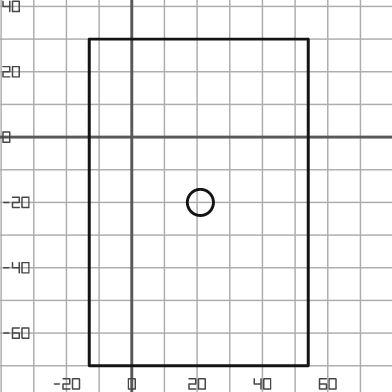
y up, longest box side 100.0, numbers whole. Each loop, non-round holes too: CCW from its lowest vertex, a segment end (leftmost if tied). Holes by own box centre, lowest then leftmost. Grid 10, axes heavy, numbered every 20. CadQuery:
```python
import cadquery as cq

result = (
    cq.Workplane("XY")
    .moveTo(-13.0, -70.0)
    .lineTo(54.0, -70.0)
    .lineTo(54.0, 30.0)
    .lineTo(-13.0, 30.0)
    .close()
    .moveTo(21.0, -20.0)
    .circle(4.0)
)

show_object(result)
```